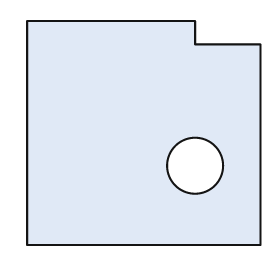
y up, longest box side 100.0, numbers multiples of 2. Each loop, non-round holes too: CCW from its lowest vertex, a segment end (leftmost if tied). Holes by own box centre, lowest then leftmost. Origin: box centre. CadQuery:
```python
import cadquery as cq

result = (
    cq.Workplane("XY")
    .moveTo(-50.0, -48.0)
    .lineTo(50.0, -48.0)
    .lineTo(50.0, 38.0)
    .lineTo(22.0, 38.0)
    .lineTo(22.0, 48.0)
    .lineTo(-50.0, 48.0)
    .close()
    .moveTo(22.0, -14.0)
    .circle(12.0)
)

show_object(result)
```